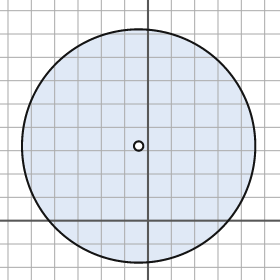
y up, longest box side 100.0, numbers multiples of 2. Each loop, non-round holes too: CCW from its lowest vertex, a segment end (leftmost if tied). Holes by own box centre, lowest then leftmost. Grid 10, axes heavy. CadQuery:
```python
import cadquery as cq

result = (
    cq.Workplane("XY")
    .moveTo(-4.0, 32.0)
    .circle(50.0)
    .moveTo(-4.0, 32.0)
    .circle(2.0)
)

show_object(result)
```